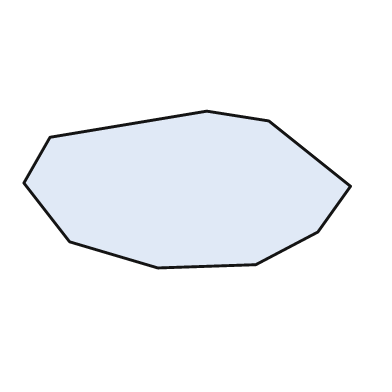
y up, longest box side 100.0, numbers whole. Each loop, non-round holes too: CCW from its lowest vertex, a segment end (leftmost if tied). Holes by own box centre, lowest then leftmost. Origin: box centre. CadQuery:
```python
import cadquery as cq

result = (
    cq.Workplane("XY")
    .moveTo(-9.0, -24.0)
    .lineTo(21.0, -23.0)
    .lineTo(40.0, -13.0)
    .lineTo(50.0, 1.0)
    .lineTo(25.0, 21.0)
    .lineTo(6.0, 24.0)
    .lineTo(-42.0, 16.0)
    .lineTo(-50.0, 2.0)
    .lineTo(-36.0, -16.0)
    .close()
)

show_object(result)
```